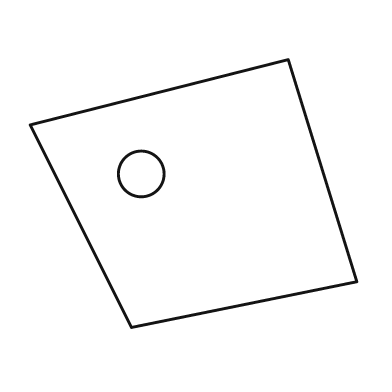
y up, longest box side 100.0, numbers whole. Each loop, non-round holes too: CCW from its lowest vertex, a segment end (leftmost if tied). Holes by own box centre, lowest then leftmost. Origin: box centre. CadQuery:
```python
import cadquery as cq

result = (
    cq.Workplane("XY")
    .moveTo(-19.0, -41.0)
    .lineTo(50.0, -27.0)
    .lineTo(29.0, 41.0)
    .lineTo(-50.0, 21.0)
    .close()
    .moveTo(-16.0, 6.0)
    .circle(7.0)
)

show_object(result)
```